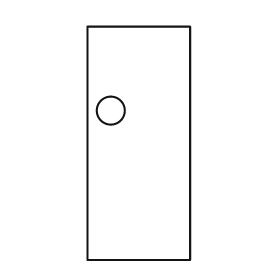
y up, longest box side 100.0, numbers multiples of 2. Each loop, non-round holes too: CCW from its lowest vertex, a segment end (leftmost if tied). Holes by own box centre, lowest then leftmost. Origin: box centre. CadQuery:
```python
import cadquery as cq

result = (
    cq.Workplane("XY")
    .moveTo(-22.0, -50.0)
    .lineTo(22.0, -50.0)
    .lineTo(22.0, 50.0)
    .lineTo(-22.0, 50.0)
    .close()
    .moveTo(-12.0, 14.0)
    .circle(6.0)
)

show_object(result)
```